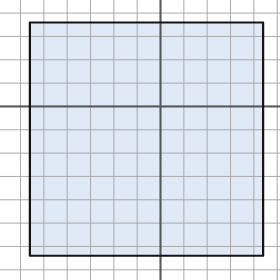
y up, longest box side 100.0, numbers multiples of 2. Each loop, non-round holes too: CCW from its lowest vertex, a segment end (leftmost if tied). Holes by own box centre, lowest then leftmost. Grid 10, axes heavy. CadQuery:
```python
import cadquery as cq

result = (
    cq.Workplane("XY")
    .moveTo(-56.0, -64.0)
    .lineTo(44.0, -64.0)
    .lineTo(44.0, 36.0)
    .lineTo(-56.0, 36.0)
    .close()
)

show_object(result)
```